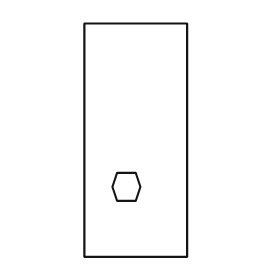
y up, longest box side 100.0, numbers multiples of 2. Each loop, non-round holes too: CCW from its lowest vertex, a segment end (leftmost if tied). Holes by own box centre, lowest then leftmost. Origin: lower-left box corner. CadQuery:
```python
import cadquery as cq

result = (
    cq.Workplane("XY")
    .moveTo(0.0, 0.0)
    .lineTo(44.0, 0.0)
    .lineTo(44.0, 100.0)
    .lineTo(0.0, 100.0)
    .close()
    .moveTo(14.0, 24.0)
    .lineTo(22.0, 24.0)
    .lineTo(24.0, 30.0)
    .lineTo(22.0, 36.0)
    .lineTo(14.0, 36.0)
    .lineTo(12.0, 30.0)
    .close()
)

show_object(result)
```